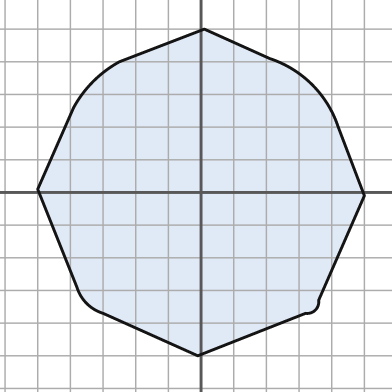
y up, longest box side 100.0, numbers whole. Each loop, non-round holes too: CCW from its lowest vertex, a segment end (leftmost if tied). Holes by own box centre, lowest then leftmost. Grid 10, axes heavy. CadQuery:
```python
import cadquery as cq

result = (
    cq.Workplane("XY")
    .moveTo(-1.0, -50.0)
    .lineTo(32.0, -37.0)
    .threePointArc((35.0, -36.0), (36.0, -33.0))
    .lineTo(50.0, -1.0)
    .lineTo(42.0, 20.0)
    .threePointArc((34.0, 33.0), (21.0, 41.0))
    .lineTo(1.0, 50.0)
    .lineTo(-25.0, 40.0)
    .threePointArc((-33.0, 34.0), (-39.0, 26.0))
    .lineTo(-50.0, 1.0)
    .lineTo(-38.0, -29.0)
    .threePointArc((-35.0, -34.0), (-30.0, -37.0))
    .close()
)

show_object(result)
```